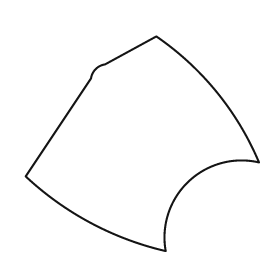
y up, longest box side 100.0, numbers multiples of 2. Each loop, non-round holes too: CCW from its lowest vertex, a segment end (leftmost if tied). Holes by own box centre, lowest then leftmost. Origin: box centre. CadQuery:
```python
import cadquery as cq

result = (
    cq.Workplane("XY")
    .moveTo(10.0, -46.0)
    .threePointArc((20.0, -16.0), (50.0, -8.0))
    .threePointArc((32.0, 22.0), (6.0, 46.0))
    .lineTo(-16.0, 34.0)
    .threePointArc((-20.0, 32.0), (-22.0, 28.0))
    .lineTo(-50.0, -14.0)
    .threePointArc((-22.0, -34.0), (10.0, -46.0))
    .close()
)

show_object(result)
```